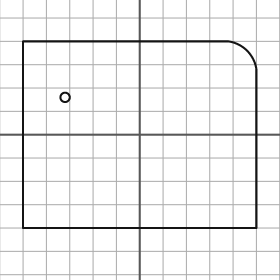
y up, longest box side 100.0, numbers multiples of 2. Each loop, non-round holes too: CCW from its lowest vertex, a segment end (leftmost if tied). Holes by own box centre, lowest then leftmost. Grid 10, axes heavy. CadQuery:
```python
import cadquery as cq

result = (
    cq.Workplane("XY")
    .moveTo(-50.0, -40.0)
    .lineTo(50.0, -40.0)
    .lineTo(50.0, 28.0)
    .threePointArc((46.0, 36.0), (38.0, 40.0))
    .lineTo(-50.0, 40.0)
    .close()
    .moveTo(-32.0, 16.0)
    .circle(2.0)
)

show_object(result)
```